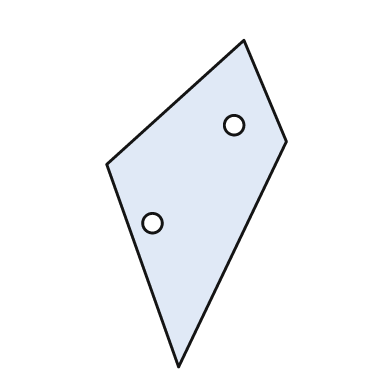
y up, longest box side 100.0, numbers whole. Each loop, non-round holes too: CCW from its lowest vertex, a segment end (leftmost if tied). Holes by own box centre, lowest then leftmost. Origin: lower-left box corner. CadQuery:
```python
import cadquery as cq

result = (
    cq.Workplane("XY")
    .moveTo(22.0, 0.0)
    .lineTo(55.0, 69.0)
    .lineTo(42.0, 100.0)
    .lineTo(0.0, 62.0)
    .close()
    .moveTo(14.0, 44.0)
    .circle(3.0)
    .moveTo(39.0, 74.0)
    .circle(3.0)
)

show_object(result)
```